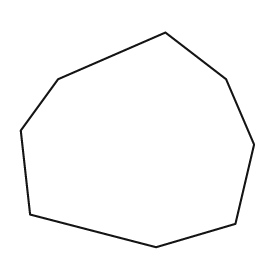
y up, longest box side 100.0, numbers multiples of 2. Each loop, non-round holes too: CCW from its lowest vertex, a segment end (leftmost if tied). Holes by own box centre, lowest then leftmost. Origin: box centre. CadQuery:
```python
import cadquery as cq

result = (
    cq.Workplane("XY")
    .moveTo(8.0, -46.0)
    .lineTo(42.0, -36.0)
    .lineTo(50.0, -2.0)
    .lineTo(38.0, 26.0)
    .lineTo(12.0, 46.0)
    .lineTo(-34.0, 26.0)
    .lineTo(-50.0, 4.0)
    .lineTo(-46.0, -32.0)
    .close()
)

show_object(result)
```